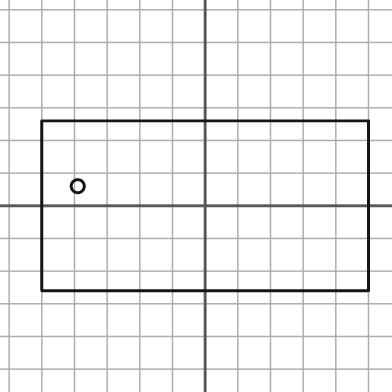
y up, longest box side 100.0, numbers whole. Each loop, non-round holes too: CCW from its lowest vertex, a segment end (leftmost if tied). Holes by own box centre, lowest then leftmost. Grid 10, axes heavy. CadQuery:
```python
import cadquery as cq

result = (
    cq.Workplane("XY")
    .moveTo(-50.0, -26.0)
    .lineTo(50.0, -26.0)
    .lineTo(50.0, 26.0)
    .lineTo(-50.0, 26.0)
    .close()
    .moveTo(-39.0, 6.0)
    .circle(2.0)
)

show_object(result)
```